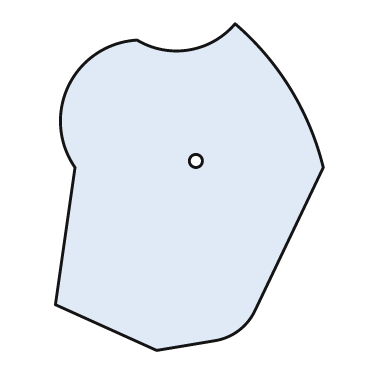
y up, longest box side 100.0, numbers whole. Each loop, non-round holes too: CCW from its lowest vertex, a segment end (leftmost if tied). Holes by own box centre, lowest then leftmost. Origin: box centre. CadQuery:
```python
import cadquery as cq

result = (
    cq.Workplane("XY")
    .moveTo(-10.0, -50.0)
    .lineTo(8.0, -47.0)
    .threePointArc((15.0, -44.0), (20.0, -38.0))
    .lineTo(41.0, 6.0)
    .threePointArc((31.0, 30.0), (14.0, 50.0))
    .threePointArc((0.0, 42.0), (-16.0, 45.0))
    .threePointArc((-37.0, 31.0), (-35.0, 6.0))
    .lineTo(-41.0, -36.0)
    .close()
    .moveTo(2.0, 8.0)
    .circle(2.0)
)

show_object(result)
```